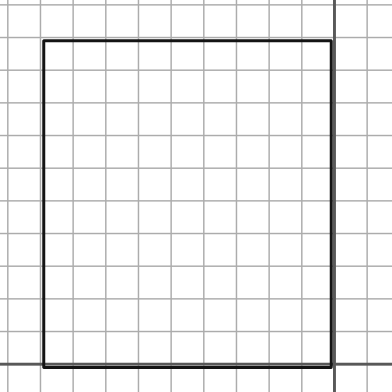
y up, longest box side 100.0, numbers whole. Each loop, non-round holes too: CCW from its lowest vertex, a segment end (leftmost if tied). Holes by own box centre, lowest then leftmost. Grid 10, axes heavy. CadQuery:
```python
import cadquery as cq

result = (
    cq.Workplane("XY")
    .moveTo(-89.0, -1.0)
    .lineTo(-1.0, -1.0)
    .lineTo(-1.0, 99.0)
    .lineTo(-89.0, 99.0)
    .close()
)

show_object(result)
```